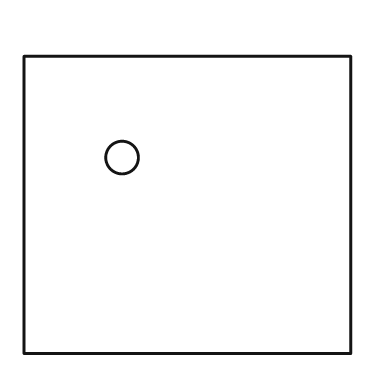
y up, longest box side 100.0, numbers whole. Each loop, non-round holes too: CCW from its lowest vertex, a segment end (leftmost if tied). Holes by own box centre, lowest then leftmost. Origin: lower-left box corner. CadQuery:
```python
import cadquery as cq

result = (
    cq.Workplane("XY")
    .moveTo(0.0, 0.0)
    .lineTo(100.0, 0.0)
    .lineTo(100.0, 91.0)
    .lineTo(0.0, 91.0)
    .close()
    .moveTo(30.0, 60.0)
    .circle(5.0)
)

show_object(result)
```